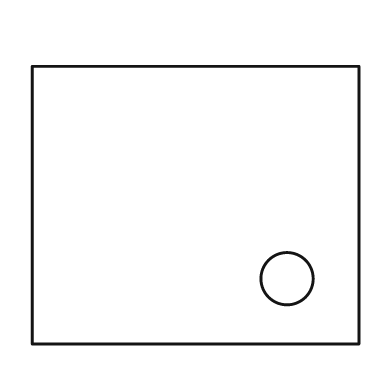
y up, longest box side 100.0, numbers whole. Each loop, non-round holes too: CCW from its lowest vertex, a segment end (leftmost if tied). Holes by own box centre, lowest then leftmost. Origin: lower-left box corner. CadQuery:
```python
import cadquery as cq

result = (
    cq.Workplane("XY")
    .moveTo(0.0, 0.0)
    .lineTo(100.0, 0.0)
    .lineTo(100.0, 85.0)
    .lineTo(0.0, 85.0)
    .close()
    .moveTo(78.0, 20.0)
    .circle(8.0)
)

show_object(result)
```